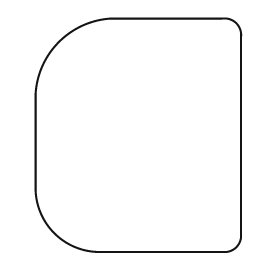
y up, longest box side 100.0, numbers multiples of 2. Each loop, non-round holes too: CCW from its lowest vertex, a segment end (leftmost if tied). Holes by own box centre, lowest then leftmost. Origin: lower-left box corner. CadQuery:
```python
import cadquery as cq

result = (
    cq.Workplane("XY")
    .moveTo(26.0, 0.0)
    .lineTo(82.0, 0.0)
    .threePointArc((86.0, 2.0), (88.0, 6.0))
    .lineTo(88.0, 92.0)
    .threePointArc((86.0, 98.0), (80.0, 100.0))
    .lineTo(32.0, 100.0)
    .threePointArc((10.0, 90.0), (0.0, 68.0))
    .lineTo(0.0, 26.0)
    .threePointArc((8.0, 8.0), (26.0, 0.0))
    .close()
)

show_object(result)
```